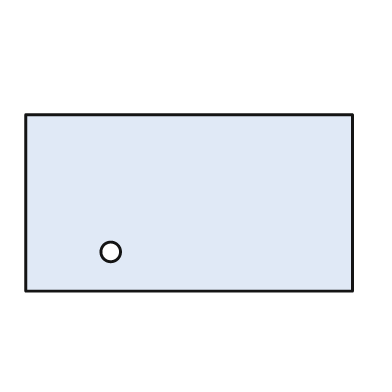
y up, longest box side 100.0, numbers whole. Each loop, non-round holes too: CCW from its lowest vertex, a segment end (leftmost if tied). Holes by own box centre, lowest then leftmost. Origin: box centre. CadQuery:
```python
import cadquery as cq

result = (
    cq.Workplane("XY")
    .moveTo(-50.0, -27.0)
    .lineTo(50.0, -27.0)
    .lineTo(50.0, 27.0)
    .lineTo(-50.0, 27.0)
    .close()
    .moveTo(-24.0, -15.0)
    .circle(3.0)
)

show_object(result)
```